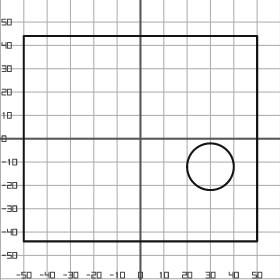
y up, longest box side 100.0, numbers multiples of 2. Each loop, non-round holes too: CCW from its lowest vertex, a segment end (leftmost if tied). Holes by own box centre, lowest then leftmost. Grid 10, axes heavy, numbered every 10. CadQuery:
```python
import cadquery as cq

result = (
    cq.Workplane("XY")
    .moveTo(-50.0, -44.0)
    .lineTo(50.0, -44.0)
    .lineTo(50.0, 44.0)
    .lineTo(-50.0, 44.0)
    .close()
    .moveTo(30.0, -12.0)
    .circle(10.0)
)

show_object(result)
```